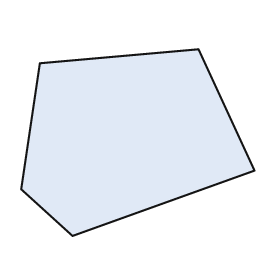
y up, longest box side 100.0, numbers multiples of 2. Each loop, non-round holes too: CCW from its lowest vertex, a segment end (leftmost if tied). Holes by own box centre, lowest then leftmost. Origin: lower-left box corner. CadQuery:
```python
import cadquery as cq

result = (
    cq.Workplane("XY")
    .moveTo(22.0, 0.0)
    .lineTo(100.0, 28.0)
    .lineTo(76.0, 80.0)
    .lineTo(8.0, 74.0)
    .lineTo(0.0, 20.0)
    .close()
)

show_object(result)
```